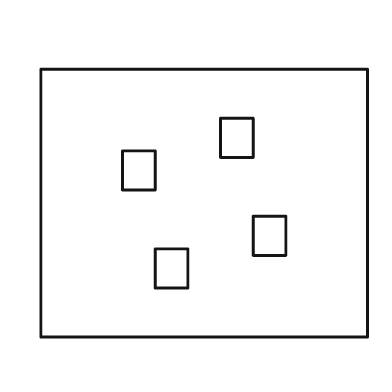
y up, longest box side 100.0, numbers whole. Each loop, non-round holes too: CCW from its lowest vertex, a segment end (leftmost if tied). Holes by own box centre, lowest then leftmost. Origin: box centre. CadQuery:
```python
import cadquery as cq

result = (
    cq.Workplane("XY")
    .moveTo(-50.0, -41.0)
    .lineTo(50.0, -41.0)
    .lineTo(50.0, 41.0)
    .lineTo(-50.0, 41.0)
    .close()
    .moveTo(-15.0, -26.0)
    .lineTo(-5.0, -26.0)
    .lineTo(-5.0, -14.0)
    .lineTo(-15.0, -14.0)
    .close()
    .moveTo(15.0, -16.0)
    .lineTo(25.0, -16.0)
    .lineTo(25.0, -4.0)
    .lineTo(15.0, -4.0)
    .close()
    .moveTo(-25.0, 4.0)
    .lineTo(-15.0, 4.0)
    .lineTo(-15.0, 16.0)
    .lineTo(-25.0, 16.0)
    .close()
    .moveTo(5.0, 14.0)
    .lineTo(15.0, 14.0)
    .lineTo(15.0, 26.0)
    .lineTo(5.0, 26.0)
    .close()
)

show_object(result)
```